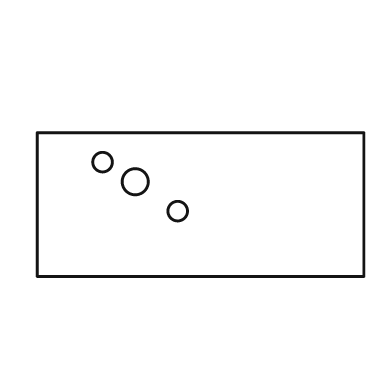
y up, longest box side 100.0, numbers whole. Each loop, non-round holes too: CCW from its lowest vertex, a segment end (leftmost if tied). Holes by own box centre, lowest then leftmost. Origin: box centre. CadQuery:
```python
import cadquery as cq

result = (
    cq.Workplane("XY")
    .moveTo(-50.0, -22.0)
    .lineTo(50.0, -22.0)
    .lineTo(50.0, 22.0)
    .lineTo(-50.0, 22.0)
    .close()
    .moveTo(-7.0, -2.0)
    .circle(3.0)
    .moveTo(-20.0, 7.0)
    .circle(4.0)
    .moveTo(-30.0, 13.0)
    .circle(3.0)
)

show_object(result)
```